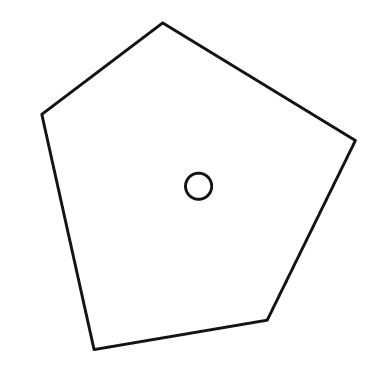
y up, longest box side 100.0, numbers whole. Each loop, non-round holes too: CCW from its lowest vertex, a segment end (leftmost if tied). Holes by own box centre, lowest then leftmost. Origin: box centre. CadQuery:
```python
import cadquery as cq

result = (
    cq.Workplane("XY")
    .moveTo(-32.0, -50.0)
    .lineTo(21.0, -41.0)
    .lineTo(48.0, 14.0)
    .lineTo(-11.0, 50.0)
    .lineTo(-48.0, 22.0)
    .close()
    .moveTo(0.0, 0.0)
    .circle(4.0)
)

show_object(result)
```